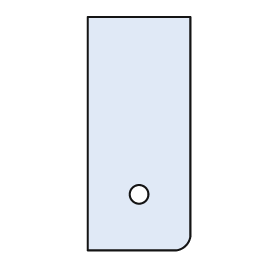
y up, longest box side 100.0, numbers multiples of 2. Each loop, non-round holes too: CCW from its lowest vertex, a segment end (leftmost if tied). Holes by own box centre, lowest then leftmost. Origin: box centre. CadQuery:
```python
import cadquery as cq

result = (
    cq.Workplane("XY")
    .moveTo(-22.0, -50.0)
    .lineTo(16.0, -50.0)
    .threePointArc((20.0, -48.0), (22.0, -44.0))
    .lineTo(22.0, 50.0)
    .lineTo(-22.0, 50.0)
    .close()
    .moveTo(0.0, -26.0)
    .circle(4.0)
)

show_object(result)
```